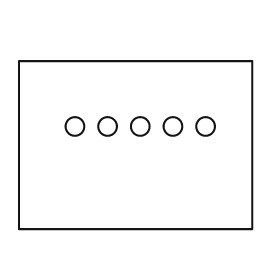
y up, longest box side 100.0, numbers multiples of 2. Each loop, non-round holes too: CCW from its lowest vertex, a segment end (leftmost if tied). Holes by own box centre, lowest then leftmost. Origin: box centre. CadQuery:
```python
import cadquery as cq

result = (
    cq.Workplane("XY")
    .moveTo(-50.0, -36.0)
    .lineTo(50.0, -36.0)
    .lineTo(50.0, 36.0)
    .lineTo(-50.0, 36.0)
    .close()
    .moveTo(-26.0, 8.0)
    .circle(4.0)
    .moveTo(-12.0, 8.0)
    .circle(4.0)
    .moveTo(2.0, 8.0)
    .circle(4.0)
    .moveTo(16.0, 8.0)
    .circle(4.0)
    .moveTo(30.0, 8.0)
    .circle(4.0)
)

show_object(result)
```